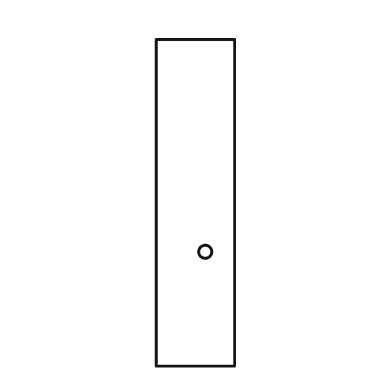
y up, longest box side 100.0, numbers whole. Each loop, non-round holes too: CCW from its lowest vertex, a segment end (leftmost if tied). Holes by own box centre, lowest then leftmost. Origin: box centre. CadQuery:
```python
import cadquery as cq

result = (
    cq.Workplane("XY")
    .moveTo(-12.0, -50.0)
    .lineTo(12.0, -50.0)
    .lineTo(12.0, 50.0)
    .lineTo(-12.0, 50.0)
    .close()
    .moveTo(3.0, -15.0)
    .circle(2.0)
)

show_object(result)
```